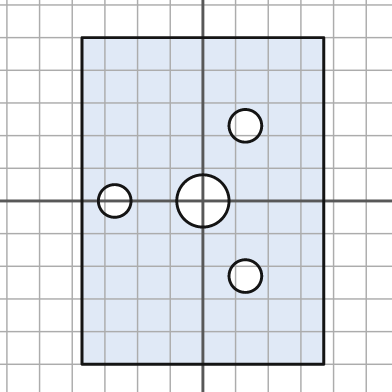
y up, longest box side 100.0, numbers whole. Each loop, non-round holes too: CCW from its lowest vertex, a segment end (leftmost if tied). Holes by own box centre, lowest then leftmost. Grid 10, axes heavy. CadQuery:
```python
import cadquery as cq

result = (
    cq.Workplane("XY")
    .moveTo(-37.0, -50.0)
    .lineTo(37.0, -50.0)
    .lineTo(37.0, 50.0)
    .lineTo(-37.0, 50.0)
    .close()
    .moveTo(13.0, -23.0)
    .circle(5.0)
    .moveTo(-27.0, 0.0)
    .circle(5.0)
    .moveTo(0.0, 0.0)
    .circle(8.0)
    .moveTo(13.0, 23.0)
    .circle(5.0)
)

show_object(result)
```